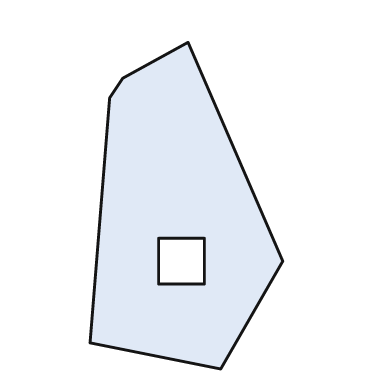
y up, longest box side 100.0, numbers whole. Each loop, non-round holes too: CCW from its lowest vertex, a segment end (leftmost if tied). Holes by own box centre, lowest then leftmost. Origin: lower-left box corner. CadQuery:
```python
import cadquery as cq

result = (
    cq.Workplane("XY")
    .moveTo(40.0, 0.0)
    .lineTo(59.0, 33.0)
    .lineTo(30.0, 100.0)
    .lineTo(10.0, 89.0)
    .lineTo(6.0, 83.0)
    .lineTo(0.0, 8.0)
    .close()
    .moveTo(21.0, 26.0)
    .lineTo(35.0, 26.0)
    .lineTo(35.0, 40.0)
    .lineTo(21.0, 40.0)
    .close()
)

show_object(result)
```